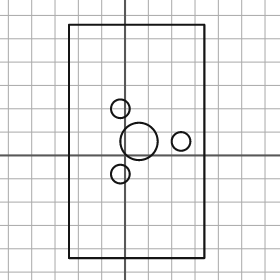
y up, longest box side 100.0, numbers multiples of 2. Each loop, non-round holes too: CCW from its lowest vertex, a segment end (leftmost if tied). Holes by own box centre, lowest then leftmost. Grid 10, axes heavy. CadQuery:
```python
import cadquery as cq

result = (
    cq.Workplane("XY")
    .moveTo(-24.0, -44.0)
    .lineTo(34.0, -44.0)
    .lineTo(34.0, 56.0)
    .lineTo(-24.0, 56.0)
    .close()
    .moveTo(-2.0, -8.0)
    .circle(4.0)
    .moveTo(6.0, 6.0)
    .circle(8.0)
    .moveTo(24.0, 6.0)
    .circle(4.0)
    .moveTo(-2.0, 20.0)
    .circle(4.0)
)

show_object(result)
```